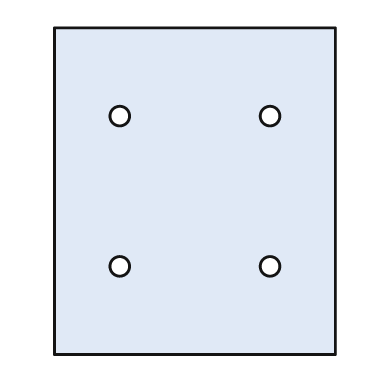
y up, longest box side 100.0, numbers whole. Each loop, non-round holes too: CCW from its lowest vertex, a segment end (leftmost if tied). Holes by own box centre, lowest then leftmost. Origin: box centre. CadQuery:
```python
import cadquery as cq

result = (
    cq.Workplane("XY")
    .moveTo(-43.0, -50.0)
    .lineTo(43.0, -50.0)
    .lineTo(43.0, 50.0)
    .lineTo(-43.0, 50.0)
    .close()
    .moveTo(-23.0, -23.0)
    .circle(3.0)
    .moveTo(23.0, -23.0)
    .circle(3.0)
    .moveTo(-23.0, 23.0)
    .circle(3.0)
    .moveTo(23.0, 23.0)
    .circle(3.0)
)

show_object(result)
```